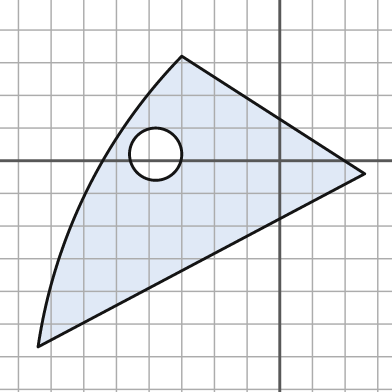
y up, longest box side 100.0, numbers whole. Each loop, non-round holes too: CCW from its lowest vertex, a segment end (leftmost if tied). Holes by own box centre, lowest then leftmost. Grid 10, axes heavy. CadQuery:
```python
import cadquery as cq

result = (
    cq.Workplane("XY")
    .moveTo(-74.0, -57.0)
    .lineTo(26.0, -4.0)
    .lineTo(-30.0, 32.0)
    .threePointArc((-59.0, -9.0), (-74.0, -57.0))
    .close()
    .moveTo(-38.0, 2.0)
    .circle(8.0)
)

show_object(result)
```